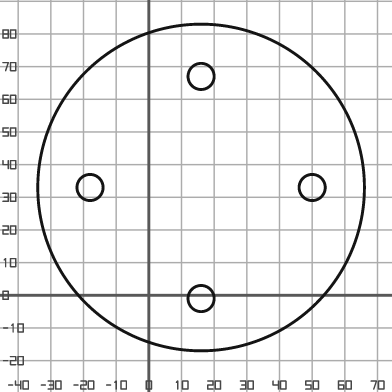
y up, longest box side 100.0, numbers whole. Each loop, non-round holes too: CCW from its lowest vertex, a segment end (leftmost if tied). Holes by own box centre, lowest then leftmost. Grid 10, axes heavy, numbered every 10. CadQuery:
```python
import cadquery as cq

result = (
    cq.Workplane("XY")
    .moveTo(16.0, 33.0)
    .circle(50.0)
    .moveTo(16.0, -1.0)
    .circle(4.0)
    .moveTo(-18.0, 33.0)
    .circle(4.0)
    .moveTo(50.0, 33.0)
    .circle(4.0)
    .moveTo(16.0, 67.0)
    .circle(4.0)
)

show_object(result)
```